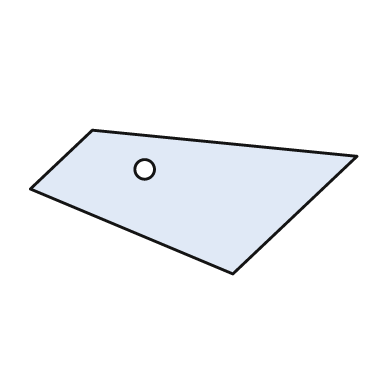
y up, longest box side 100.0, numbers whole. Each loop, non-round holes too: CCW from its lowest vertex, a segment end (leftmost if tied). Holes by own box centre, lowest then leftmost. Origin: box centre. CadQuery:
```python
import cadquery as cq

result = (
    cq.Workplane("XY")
    .moveTo(12.0, -22.0)
    .lineTo(50.0, 14.0)
    .lineTo(-31.0, 22.0)
    .lineTo(-50.0, 4.0)
    .close()
    .moveTo(-15.0, 10.0)
    .circle(3.0)
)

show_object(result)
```